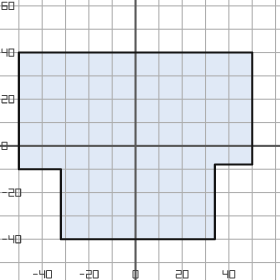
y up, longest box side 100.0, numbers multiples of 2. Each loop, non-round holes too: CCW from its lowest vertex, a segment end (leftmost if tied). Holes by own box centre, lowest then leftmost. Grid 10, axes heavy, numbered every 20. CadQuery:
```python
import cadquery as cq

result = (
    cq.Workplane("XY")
    .moveTo(-32.0, -40.0)
    .lineTo(34.0, -40.0)
    .lineTo(34.0, -8.0)
    .lineTo(50.0, -8.0)
    .lineTo(50.0, 40.0)
    .lineTo(-50.0, 40.0)
    .lineTo(-50.0, -10.0)
    .lineTo(-32.0, -10.0)
    .close()
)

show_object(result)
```